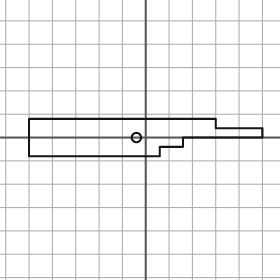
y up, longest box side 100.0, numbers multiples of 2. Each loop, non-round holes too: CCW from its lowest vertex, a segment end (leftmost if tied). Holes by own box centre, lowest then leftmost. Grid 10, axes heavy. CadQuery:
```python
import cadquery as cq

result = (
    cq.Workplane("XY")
    .moveTo(-50.0, -8.0)
    .lineTo(6.0, -8.0)
    .lineTo(6.0, -4.0)
    .lineTo(16.0, -4.0)
    .lineTo(16.0, 0.0)
    .lineTo(50.0, 0.0)
    .lineTo(50.0, 4.0)
    .lineTo(30.0, 4.0)
    .lineTo(30.0, 8.0)
    .lineTo(-50.0, 8.0)
    .close()
    .moveTo(-4.0, 0.0)
    .circle(2.0)
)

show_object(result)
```